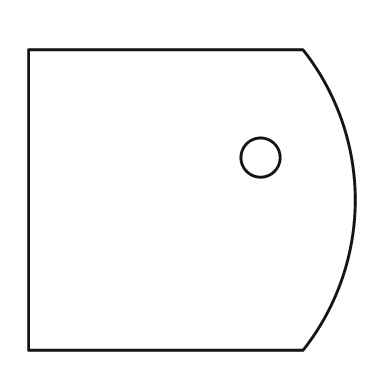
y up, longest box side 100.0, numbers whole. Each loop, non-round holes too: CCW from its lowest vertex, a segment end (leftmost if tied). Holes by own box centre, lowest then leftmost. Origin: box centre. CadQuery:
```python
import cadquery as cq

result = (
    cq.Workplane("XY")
    .moveTo(-50.0, -46.0)
    .lineTo(34.0, -46.0)
    .threePointArc((50.0, 0.0), (34.0, 46.0))
    .lineTo(-50.0, 46.0)
    .close()
    .moveTo(21.0, 13.0)
    .circle(6.0)
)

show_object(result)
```